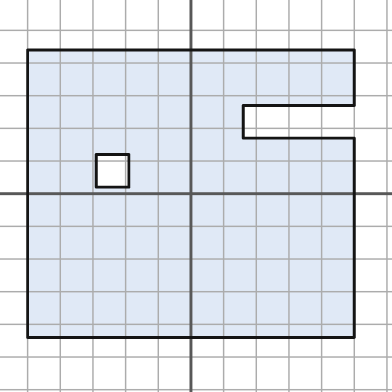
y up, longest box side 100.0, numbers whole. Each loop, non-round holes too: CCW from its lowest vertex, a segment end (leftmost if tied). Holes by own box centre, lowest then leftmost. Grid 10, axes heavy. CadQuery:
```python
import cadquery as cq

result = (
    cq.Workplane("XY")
    .moveTo(-50.0, -44.0)
    .lineTo(50.0, -44.0)
    .lineTo(50.0, 17.0)
    .lineTo(16.0, 17.0)
    .lineTo(16.0, 27.0)
    .lineTo(50.0, 27.0)
    .lineTo(50.0, 44.0)
    .lineTo(-50.0, 44.0)
    .close()
    .moveTo(-29.0, 2.0)
    .lineTo(-19.0, 2.0)
    .lineTo(-19.0, 12.0)
    .lineTo(-29.0, 12.0)
    .close()
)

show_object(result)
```